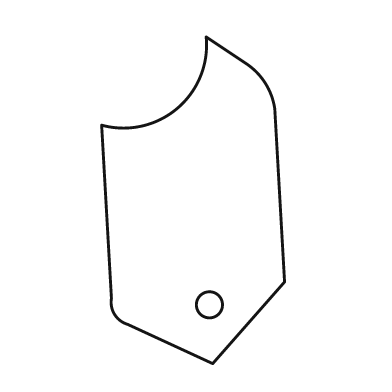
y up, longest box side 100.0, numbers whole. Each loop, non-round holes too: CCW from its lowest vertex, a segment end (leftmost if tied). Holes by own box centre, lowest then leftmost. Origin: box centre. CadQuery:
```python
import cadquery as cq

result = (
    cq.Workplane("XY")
    .moveTo(6.0, -50.0)
    .lineTo(28.0, -25.0)
    .lineTo(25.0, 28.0)
    .threePointArc((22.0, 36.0), (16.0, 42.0))
    .lineTo(4.0, 50.0)
    .threePointArc((-5.0, 28.0), (-28.0, 23.0))
    .lineTo(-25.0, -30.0)
    .threePointArc((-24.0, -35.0), (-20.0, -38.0))
    .close()
    .moveTo(5.0, -32.0)
    .circle(4.0)
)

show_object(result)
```